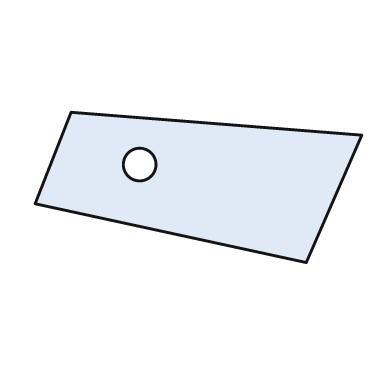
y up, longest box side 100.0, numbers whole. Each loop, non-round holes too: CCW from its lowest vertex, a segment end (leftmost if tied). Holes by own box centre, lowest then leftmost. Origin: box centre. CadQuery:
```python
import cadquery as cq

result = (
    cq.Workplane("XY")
    .moveTo(33.0, -23.0)
    .lineTo(50.0, 16.0)
    .lineTo(-39.0, 23.0)
    .lineTo(-50.0, -5.0)
    .close()
    .moveTo(-18.0, 7.0)
    .circle(5.0)
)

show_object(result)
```